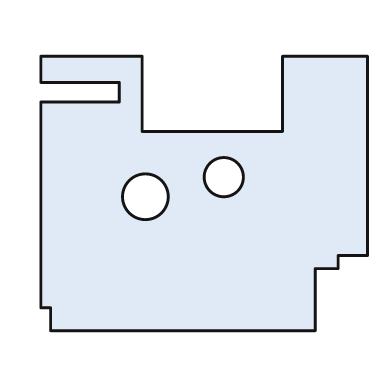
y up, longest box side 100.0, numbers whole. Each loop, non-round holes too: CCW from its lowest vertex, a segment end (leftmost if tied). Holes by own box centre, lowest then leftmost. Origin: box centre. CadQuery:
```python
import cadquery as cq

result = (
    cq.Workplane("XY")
    .moveTo(-47.0, -42.0)
    .lineTo(34.0, -42.0)
    .lineTo(34.0, -23.0)
    .lineTo(41.0, -23.0)
    .lineTo(41.0, -19.0)
    .lineTo(50.0, -19.0)
    .lineTo(50.0, 42.0)
    .lineTo(24.0, 42.0)
    .lineTo(24.0, 19.0)
    .lineTo(-19.0, 19.0)
    .lineTo(-19.0, 42.0)
    .lineTo(-50.0, 42.0)
    .lineTo(-50.0, 34.0)
    .lineTo(-26.0, 34.0)
    .lineTo(-26.0, 28.0)
    .lineTo(-50.0, 28.0)
    .lineTo(-50.0, -35.0)
    .lineTo(-47.0, -35.0)
    .close()
    .moveTo(-18.0, -1.0)
    .circle(7.0)
    .moveTo(6.0, 5.0)
    .circle(6.0)
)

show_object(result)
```